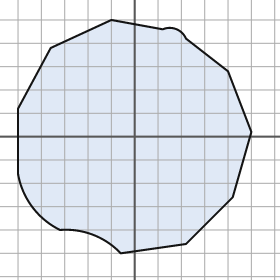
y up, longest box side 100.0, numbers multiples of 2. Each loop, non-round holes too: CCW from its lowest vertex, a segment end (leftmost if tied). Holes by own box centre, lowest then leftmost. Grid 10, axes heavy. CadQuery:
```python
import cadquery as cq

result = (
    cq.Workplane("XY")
    .moveTo(-6.0, -50.0)
    .lineTo(22.0, -46.0)
    .lineTo(42.0, -26.0)
    .lineTo(50.0, 2.0)
    .lineTo(40.0, 28.0)
    .lineTo(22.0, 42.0)
    .threePointArc((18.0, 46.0), (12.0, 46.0))
    .lineTo(-10.0, 50.0)
    .lineTo(-36.0, 38.0)
    .lineTo(-50.0, 12.0)
    .lineTo(-50.0, -16.0)
    .threePointArc((-44.0, -30.0), (-32.0, -40.0))
    .threePointArc((-18.0, -42.0), (-6.0, -50.0))
    .close()
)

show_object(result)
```